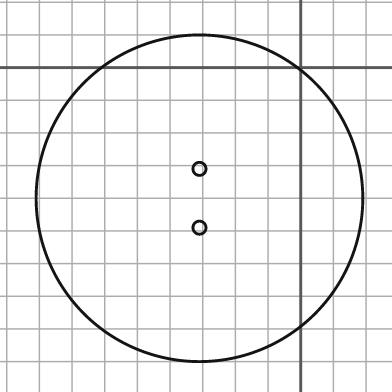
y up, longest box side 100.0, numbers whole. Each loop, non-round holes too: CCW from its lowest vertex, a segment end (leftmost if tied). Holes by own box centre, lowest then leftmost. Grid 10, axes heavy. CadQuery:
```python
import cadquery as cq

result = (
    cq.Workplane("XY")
    .moveTo(-31.0, -40.0)
    .circle(50.0)
    .moveTo(-31.0, -49.0)
    .circle(2.0)
    .moveTo(-31.0, -31.0)
    .circle(2.0)
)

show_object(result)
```